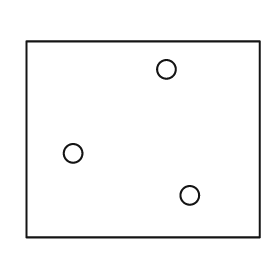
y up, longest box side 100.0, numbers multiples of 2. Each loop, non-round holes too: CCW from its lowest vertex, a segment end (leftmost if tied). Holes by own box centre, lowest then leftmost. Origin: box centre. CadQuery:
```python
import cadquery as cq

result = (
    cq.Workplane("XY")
    .moveTo(-50.0, -42.0)
    .lineTo(50.0, -42.0)
    .lineTo(50.0, 42.0)
    .lineTo(-50.0, 42.0)
    .close()
    .moveTo(20.0, -24.0)
    .circle(4.0)
    .moveTo(-30.0, -6.0)
    .circle(4.0)
    .moveTo(10.0, 30.0)
    .circle(4.0)
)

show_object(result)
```